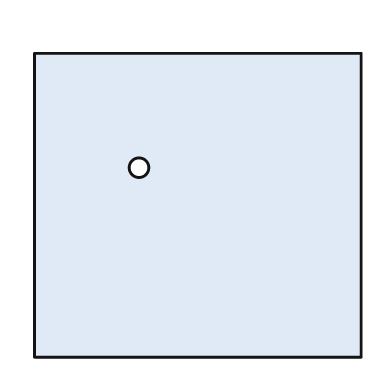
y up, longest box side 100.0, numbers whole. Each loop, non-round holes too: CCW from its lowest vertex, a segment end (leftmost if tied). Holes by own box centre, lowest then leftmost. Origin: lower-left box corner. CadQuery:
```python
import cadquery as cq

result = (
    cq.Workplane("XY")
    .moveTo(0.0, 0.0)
    .lineTo(100.0, 0.0)
    .lineTo(100.0, 93.0)
    .lineTo(0.0, 93.0)
    .close()
    .moveTo(32.0, 58.0)
    .circle(3.0)
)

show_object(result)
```